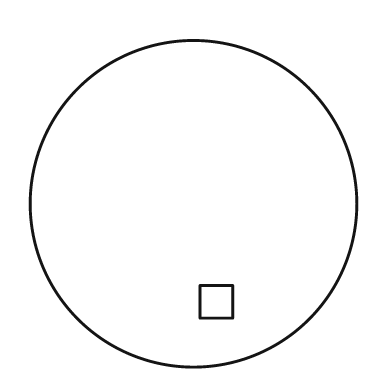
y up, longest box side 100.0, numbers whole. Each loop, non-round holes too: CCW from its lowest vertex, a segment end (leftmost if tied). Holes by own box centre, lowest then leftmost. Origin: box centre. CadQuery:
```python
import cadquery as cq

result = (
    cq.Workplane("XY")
    .moveTo(0.0, 0.0)
    .circle(50.0)
    .moveTo(2.0, -35.0)
    .lineTo(12.0, -35.0)
    .lineTo(12.0, -25.0)
    .lineTo(2.0, -25.0)
    .close()
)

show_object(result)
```